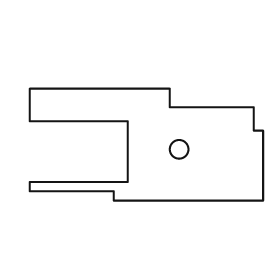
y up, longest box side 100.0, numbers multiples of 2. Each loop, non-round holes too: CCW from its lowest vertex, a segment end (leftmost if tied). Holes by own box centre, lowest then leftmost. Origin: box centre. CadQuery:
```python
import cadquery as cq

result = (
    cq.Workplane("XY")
    .moveTo(-14.0, -24.0)
    .lineTo(50.0, -24.0)
    .lineTo(50.0, 6.0)
    .lineTo(46.0, 6.0)
    .lineTo(46.0, 16.0)
    .lineTo(10.0, 16.0)
    .lineTo(10.0, 24.0)
    .lineTo(-50.0, 24.0)
    .lineTo(-50.0, 10.0)
    .lineTo(-8.0, 10.0)
    .lineTo(-8.0, -16.0)
    .lineTo(-50.0, -16.0)
    .lineTo(-50.0, -20.0)
    .lineTo(-14.0, -20.0)
    .close()
    .moveTo(14.0, -2.0)
    .circle(4.0)
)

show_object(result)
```